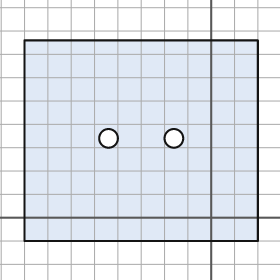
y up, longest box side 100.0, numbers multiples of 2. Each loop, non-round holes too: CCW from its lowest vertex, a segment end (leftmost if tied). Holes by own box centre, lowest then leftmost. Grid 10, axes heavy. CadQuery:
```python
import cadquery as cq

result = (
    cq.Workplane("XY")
    .moveTo(-80.0, -10.0)
    .lineTo(20.0, -10.0)
    .lineTo(20.0, 76.0)
    .lineTo(-80.0, 76.0)
    .close()
    .moveTo(-44.0, 34.0)
    .circle(4.0)
    .moveTo(-16.0, 34.0)
    .circle(4.0)
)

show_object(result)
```